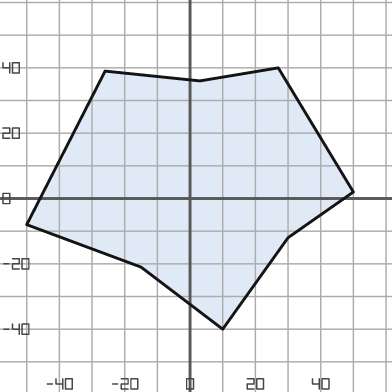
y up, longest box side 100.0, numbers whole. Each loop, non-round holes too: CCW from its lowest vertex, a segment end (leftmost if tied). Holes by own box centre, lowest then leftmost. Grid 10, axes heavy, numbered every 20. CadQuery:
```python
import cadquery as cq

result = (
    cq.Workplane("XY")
    .moveTo(10.0, -40.0)
    .lineTo(30.0, -12.0)
    .lineTo(50.0, 2.0)
    .lineTo(27.0, 40.0)
    .lineTo(3.0, 36.0)
    .lineTo(-26.0, 39.0)
    .lineTo(-50.0, -8.0)
    .lineTo(-15.0, -21.0)
    .close()
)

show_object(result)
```